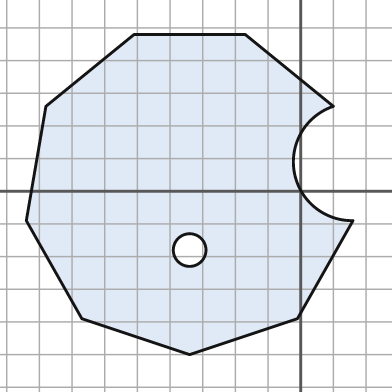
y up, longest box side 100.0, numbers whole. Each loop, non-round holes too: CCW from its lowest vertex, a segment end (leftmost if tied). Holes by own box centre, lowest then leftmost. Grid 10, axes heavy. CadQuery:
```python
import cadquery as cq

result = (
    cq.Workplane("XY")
    .moveTo(-34.0, -50.0)
    .lineTo(-1.0, -39.0)
    .lineTo(16.0, -9.0)
    .threePointArc((-2.0, 6.0), (10.0, 26.0))
    .lineTo(-17.0, 48.0)
    .lineTo(-51.0, 48.0)
    .lineTo(-78.0, 26.0)
    .lineTo(-84.0, -9.0)
    .lineTo(-67.0, -39.0)
    .close()
    .moveTo(-34.0, -18.0)
    .circle(5.0)
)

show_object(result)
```